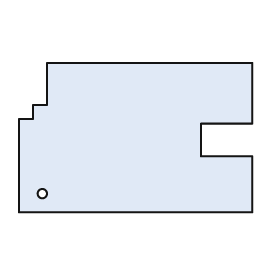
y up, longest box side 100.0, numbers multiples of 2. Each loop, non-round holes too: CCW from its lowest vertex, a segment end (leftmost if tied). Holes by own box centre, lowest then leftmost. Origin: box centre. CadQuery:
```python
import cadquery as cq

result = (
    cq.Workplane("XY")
    .moveTo(-50.0, -32.0)
    .lineTo(50.0, -32.0)
    .lineTo(50.0, -8.0)
    .lineTo(28.0, -8.0)
    .lineTo(28.0, 6.0)
    .lineTo(50.0, 6.0)
    .lineTo(50.0, 32.0)
    .lineTo(-38.0, 32.0)
    .lineTo(-38.0, 14.0)
    .lineTo(-44.0, 14.0)
    .lineTo(-44.0, 8.0)
    .lineTo(-50.0, 8.0)
    .close()
    .moveTo(-40.0, -24.0)
    .circle(2.0)
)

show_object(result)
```